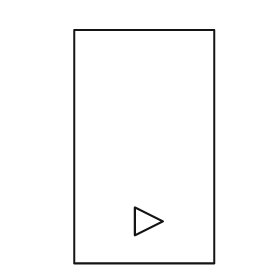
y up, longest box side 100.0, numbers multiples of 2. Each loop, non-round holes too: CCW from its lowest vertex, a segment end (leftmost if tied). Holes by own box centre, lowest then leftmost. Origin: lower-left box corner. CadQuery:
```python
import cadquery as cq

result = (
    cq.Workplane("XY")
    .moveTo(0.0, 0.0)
    .lineTo(60.0, 0.0)
    .lineTo(60.0, 100.0)
    .lineTo(0.0, 100.0)
    .close()
    .moveTo(26.0, 12.0)
    .lineTo(38.0, 18.0)
    .lineTo(26.0, 24.0)
    .close()
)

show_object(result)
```